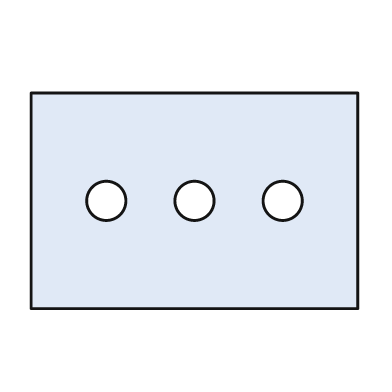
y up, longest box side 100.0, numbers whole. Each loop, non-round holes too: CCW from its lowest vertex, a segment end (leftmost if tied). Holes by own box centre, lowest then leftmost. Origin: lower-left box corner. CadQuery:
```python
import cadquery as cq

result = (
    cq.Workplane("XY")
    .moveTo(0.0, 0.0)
    .lineTo(100.0, 0.0)
    .lineTo(100.0, 66.0)
    .lineTo(0.0, 66.0)
    .close()
    .moveTo(23.0, 33.0)
    .circle(6.0)
    .moveTo(50.0, 33.0)
    .circle(6.0)
    .moveTo(77.0, 33.0)
    .circle(6.0)
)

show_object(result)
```